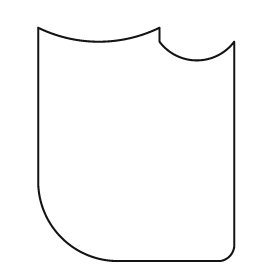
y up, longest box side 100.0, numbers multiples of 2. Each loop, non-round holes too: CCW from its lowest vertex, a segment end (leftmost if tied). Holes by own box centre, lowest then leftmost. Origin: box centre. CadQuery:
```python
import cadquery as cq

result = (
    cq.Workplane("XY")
    .moveTo(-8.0, -50.0)
    .lineTo(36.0, -50.0)
    .threePointArc((40.0, -48.0), (42.0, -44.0))
    .lineTo(42.0, 44.0)
    .threePointArc((26.0, 36.0), (10.0, 44.0))
    .lineTo(10.0, 50.0)
    .threePointArc((-16.0, 44.0), (-42.0, 50.0))
    .lineTo(-42.0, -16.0)
    .threePointArc((-32.0, -40.0), (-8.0, -50.0))
    .close()
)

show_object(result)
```